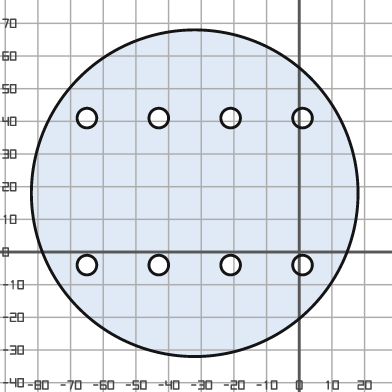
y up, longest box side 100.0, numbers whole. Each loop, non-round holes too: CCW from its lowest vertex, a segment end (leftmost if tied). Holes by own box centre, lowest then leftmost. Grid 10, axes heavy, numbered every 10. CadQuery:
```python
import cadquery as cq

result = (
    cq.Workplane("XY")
    .moveTo(-32.0, 18.0)
    .circle(50.0)
    .moveTo(-65.0, -4.0)
    .circle(3.0)
    .moveTo(-43.0, -4.0)
    .circle(3.0)
    .moveTo(-21.0, -4.0)
    .circle(3.0)
    .moveTo(1.0, -4.0)
    .circle(3.0)
    .moveTo(-65.0, 41.0)
    .circle(3.0)
    .moveTo(-43.0, 41.0)
    .circle(3.0)
    .moveTo(-21.0, 41.0)
    .circle(3.0)
    .moveTo(1.0, 41.0)
    .circle(3.0)
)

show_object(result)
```